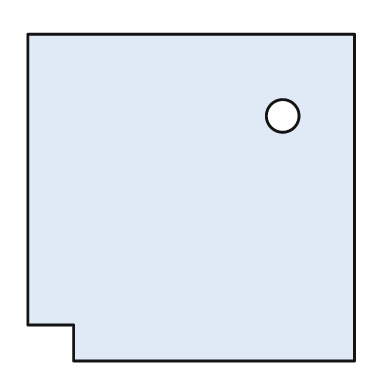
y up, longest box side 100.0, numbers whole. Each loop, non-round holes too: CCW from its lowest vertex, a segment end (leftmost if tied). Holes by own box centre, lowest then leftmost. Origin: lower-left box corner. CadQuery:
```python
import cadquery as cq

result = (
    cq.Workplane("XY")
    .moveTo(14.0, 0.0)
    .lineTo(100.0, 0.0)
    .lineTo(100.0, 100.0)
    .lineTo(0.0, 100.0)
    .lineTo(0.0, 11.0)
    .lineTo(14.0, 11.0)
    .close()
    .moveTo(78.0, 75.0)
    .circle(5.0)
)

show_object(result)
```